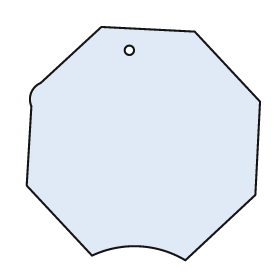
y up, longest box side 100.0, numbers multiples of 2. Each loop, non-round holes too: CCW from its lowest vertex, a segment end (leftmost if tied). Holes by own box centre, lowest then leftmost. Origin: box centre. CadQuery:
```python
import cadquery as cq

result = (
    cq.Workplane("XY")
    .moveTo(18.0, -50.0)
    .lineTo(48.0, -22.0)
    .lineTo(50.0, 18.0)
    .lineTo(22.0, 48.0)
    .lineTo(-18.0, 50.0)
    .lineTo(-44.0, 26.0)
    .threePointArc((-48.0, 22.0), (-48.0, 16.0))
    .lineTo(-50.0, -18.0)
    .lineTo(-22.0, -48.0)
    .threePointArc((-2.0, -44.0), (18.0, -50.0))
    .close()
    .moveTo(-6.0, 40.0)
    .circle(2.0)
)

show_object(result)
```